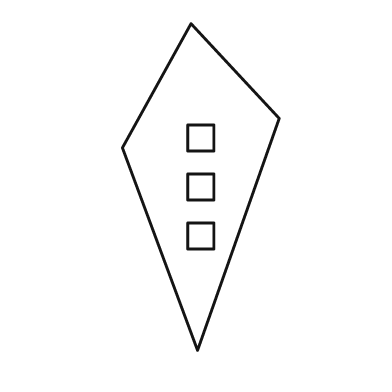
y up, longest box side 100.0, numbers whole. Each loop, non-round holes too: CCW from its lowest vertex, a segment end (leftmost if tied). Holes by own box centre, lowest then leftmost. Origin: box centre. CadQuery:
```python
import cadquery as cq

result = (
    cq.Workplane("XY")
    .moveTo(-1.0, -50.0)
    .lineTo(24.0, 21.0)
    .lineTo(-3.0, 50.0)
    .lineTo(-24.0, 12.0)
    .close()
    .moveTo(-4.0, -19.0)
    .lineTo(4.0, -19.0)
    .lineTo(4.0, -11.0)
    .lineTo(-4.0, -11.0)
    .close()
    .moveTo(-4.0, -4.0)
    .lineTo(4.0, -4.0)
    .lineTo(4.0, 4.0)
    .lineTo(-4.0, 4.0)
    .close()
    .moveTo(-4.0, 11.0)
    .lineTo(4.0, 11.0)
    .lineTo(4.0, 19.0)
    .lineTo(-4.0, 19.0)
    .close()
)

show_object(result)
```